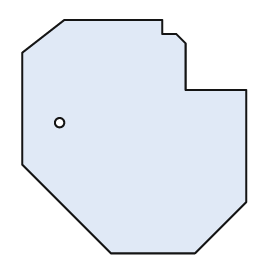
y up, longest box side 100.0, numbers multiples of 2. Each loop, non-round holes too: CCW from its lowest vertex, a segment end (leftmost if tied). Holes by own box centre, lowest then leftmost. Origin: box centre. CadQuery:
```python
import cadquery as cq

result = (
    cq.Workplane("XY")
    .moveTo(-10.0, -50.0)
    .lineTo(26.0, -50.0)
    .lineTo(48.0, -28.0)
    .lineTo(48.0, 20.0)
    .lineTo(22.0, 20.0)
    .lineTo(22.0, 40.0)
    .lineTo(18.0, 44.0)
    .lineTo(12.0, 44.0)
    .lineTo(12.0, 50.0)
    .lineTo(-30.0, 50.0)
    .lineTo(-48.0, 36.0)
    .lineTo(-48.0, -12.0)
    .close()
    .moveTo(-32.0, 6.0)
    .circle(2.0)
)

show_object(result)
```